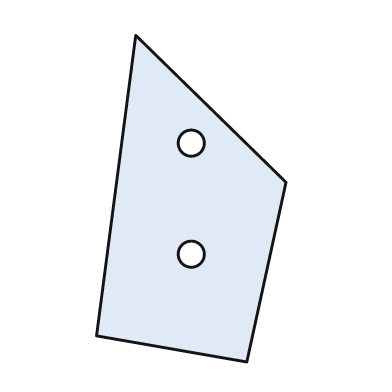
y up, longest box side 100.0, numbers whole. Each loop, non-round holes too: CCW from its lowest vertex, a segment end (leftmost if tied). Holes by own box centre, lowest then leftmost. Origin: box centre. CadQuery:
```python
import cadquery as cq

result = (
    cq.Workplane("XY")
    .moveTo(17.0, -50.0)
    .lineTo(29.0, 5.0)
    .lineTo(-17.0, 50.0)
    .lineTo(-29.0, -42.0)
    .close()
    .moveTo(0.0, -17.0)
    .circle(4.0)
    .moveTo(0.0, 17.0)
    .circle(4.0)
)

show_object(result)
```